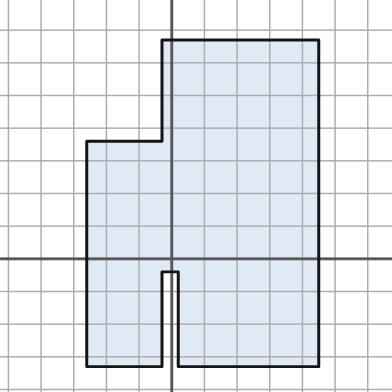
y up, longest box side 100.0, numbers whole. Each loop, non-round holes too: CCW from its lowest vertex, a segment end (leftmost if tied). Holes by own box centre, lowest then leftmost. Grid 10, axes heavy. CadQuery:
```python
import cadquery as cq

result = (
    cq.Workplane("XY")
    .moveTo(-26.0, -33.0)
    .lineTo(-3.0, -33.0)
    .lineTo(-3.0, -4.0)
    .lineTo(2.0, -4.0)
    .lineTo(2.0, -33.0)
    .lineTo(45.0, -33.0)
    .lineTo(45.0, 67.0)
    .lineTo(-3.0, 67.0)
    .lineTo(-3.0, 36.0)
    .lineTo(-26.0, 36.0)
    .close()
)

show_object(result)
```